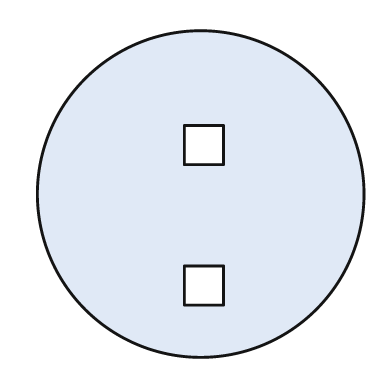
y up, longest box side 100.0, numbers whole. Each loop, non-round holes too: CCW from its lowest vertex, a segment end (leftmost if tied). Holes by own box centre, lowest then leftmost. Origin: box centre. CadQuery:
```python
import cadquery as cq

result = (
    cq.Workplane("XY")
    .moveTo(0.0, 0.0)
    .circle(50.0)
    .moveTo(-5.0, -34.0)
    .lineTo(7.0, -34.0)
    .lineTo(7.0, -22.0)
    .lineTo(-5.0, -22.0)
    .close()
    .moveTo(-5.0, 9.0)
    .lineTo(7.0, 9.0)
    .lineTo(7.0, 21.0)
    .lineTo(-5.0, 21.0)
    .close()
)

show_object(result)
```